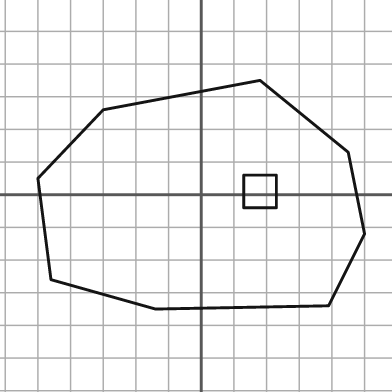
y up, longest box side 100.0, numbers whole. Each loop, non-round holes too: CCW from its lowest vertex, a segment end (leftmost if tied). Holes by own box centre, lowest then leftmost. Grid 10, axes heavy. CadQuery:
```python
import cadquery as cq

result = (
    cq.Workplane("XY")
    .moveTo(-14.0, -35.0)
    .lineTo(39.0, -34.0)
    .lineTo(50.0, -12.0)
    .lineTo(45.0, 13.0)
    .lineTo(18.0, 35.0)
    .lineTo(-30.0, 26.0)
    .lineTo(-50.0, 5.0)
    .lineTo(-46.0, -26.0)
    .close()
    .moveTo(13.0, -4.0)
    .lineTo(23.0, -4.0)
    .lineTo(23.0, 6.0)
    .lineTo(13.0, 6.0)
    .close()
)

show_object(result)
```